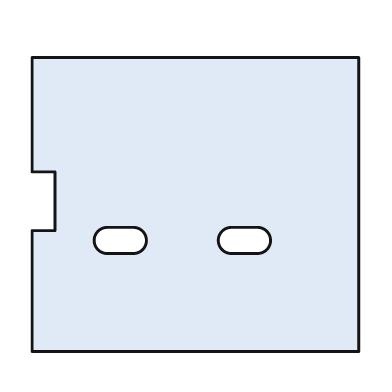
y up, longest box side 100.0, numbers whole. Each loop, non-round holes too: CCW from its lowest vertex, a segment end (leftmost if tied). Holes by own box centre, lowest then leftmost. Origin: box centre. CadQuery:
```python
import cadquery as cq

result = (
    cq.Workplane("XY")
    .moveTo(-50.0, -45.0)
    .lineTo(50.0, -45.0)
    .lineTo(50.0, 45.0)
    .lineTo(-50.0, 45.0)
    .lineTo(-50.0, 10.0)
    .lineTo(-43.0, 10.0)
    .lineTo(-43.0, -8.0)
    .lineTo(-50.0, -8.0)
    .close()
    .moveTo(-27.0, -15.0)
    .lineTo(-19.0, -15.0)
    .threePointArc((-15.0, -11.0), (-19.0, -7.0))
    .lineTo(-27.0, -7.0)
    .threePointArc((-31.0, -11.0), (-27.0, -15.0))
    .close()
    .moveTo(11.0, -15.0)
    .lineTo(19.0, -15.0)
    .threePointArc((23.0, -11.0), (19.0, -7.0))
    .lineTo(11.0, -7.0)
    .threePointArc((7.0, -11.0), (11.0, -15.0))
    .close()
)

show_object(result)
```